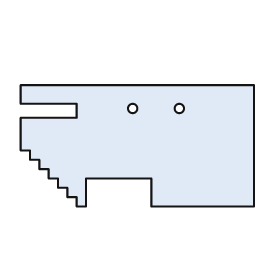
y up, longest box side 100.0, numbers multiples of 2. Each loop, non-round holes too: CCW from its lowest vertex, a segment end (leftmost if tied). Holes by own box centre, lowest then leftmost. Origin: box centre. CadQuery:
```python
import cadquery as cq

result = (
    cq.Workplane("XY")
    .moveTo(-26.0, -26.0)
    .lineTo(-22.0, -26.0)
    .lineTo(-22.0, -14.0)
    .lineTo(6.0, -14.0)
    .lineTo(6.0, -26.0)
    .lineTo(50.0, -26.0)
    .lineTo(50.0, 26.0)
    .lineTo(-50.0, 26.0)
    .lineTo(-50.0, 18.0)
    .lineTo(-26.0, 18.0)
    .lineTo(-26.0, 12.0)
    .lineTo(-50.0, 12.0)
    .lineTo(-50.0, -2.0)
    .lineTo(-46.0, -2.0)
    .lineTo(-46.0, -6.0)
    .lineTo(-42.0, -6.0)
    .lineTo(-42.0, -10.0)
    .lineTo(-38.0, -10.0)
    .lineTo(-38.0, -14.0)
    .lineTo(-34.0, -14.0)
    .lineTo(-34.0, -18.0)
    .lineTo(-30.0, -18.0)
    .lineTo(-30.0, -22.0)
    .lineTo(-26.0, -22.0)
    .close()
    .moveTo(-2.0, 16.0)
    .circle(2.0)
    .moveTo(18.0, 16.0)
    .circle(2.0)
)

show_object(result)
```